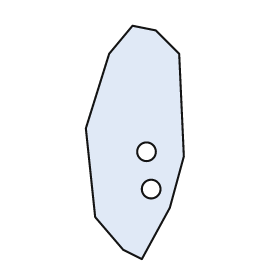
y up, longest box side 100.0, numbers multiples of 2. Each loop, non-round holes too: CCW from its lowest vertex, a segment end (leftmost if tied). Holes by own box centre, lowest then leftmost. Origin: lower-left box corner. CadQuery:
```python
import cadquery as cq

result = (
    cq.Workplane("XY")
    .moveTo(24.0, 0.0)
    .lineTo(36.0, 22.0)
    .lineTo(42.0, 44.0)
    .lineTo(40.0, 88.0)
    .lineTo(30.0, 98.0)
    .lineTo(20.0, 100.0)
    .lineTo(10.0, 88.0)
    .lineTo(0.0, 56.0)
    .lineTo(4.0, 18.0)
    .lineTo(16.0, 4.0)
    .close()
    .moveTo(28.0, 30.0)
    .circle(4.0)
    .moveTo(26.0, 46.0)
    .circle(4.0)
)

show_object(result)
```